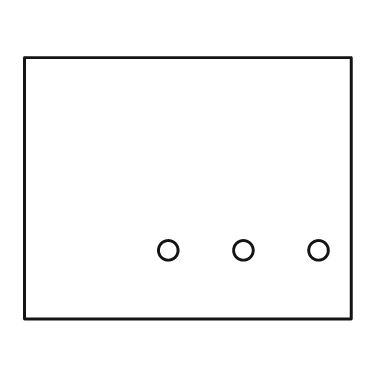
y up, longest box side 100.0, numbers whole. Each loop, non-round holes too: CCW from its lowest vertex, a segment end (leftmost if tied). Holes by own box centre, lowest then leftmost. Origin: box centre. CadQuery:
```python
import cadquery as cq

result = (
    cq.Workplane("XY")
    .moveTo(-50.0, -40.0)
    .lineTo(50.0, -40.0)
    .lineTo(50.0, 40.0)
    .lineTo(-50.0, 40.0)
    .close()
    .moveTo(-6.0, -19.0)
    .circle(3.0)
    .moveTo(17.0, -19.0)
    .circle(3.0)
    .moveTo(40.0, -19.0)
    .circle(3.0)
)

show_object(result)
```